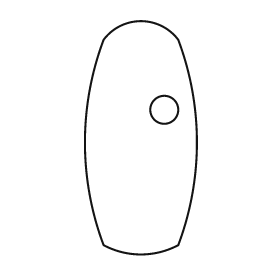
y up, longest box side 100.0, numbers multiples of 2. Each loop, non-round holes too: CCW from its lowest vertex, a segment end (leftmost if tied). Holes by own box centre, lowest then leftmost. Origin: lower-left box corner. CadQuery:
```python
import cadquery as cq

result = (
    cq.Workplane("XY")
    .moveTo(8.0, 4.0)
    .threePointArc((24.0, 0.0), (40.0, 4.0))
    .threePointArc((48.0, 48.0), (40.0, 92.0))
    .threePointArc((24.0, 100.0), (8.0, 92.0))
    .threePointArc((0.0, 48.0), (8.0, 4.0))
    .close()
    .moveTo(34.0, 62.0)
    .circle(6.0)
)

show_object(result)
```